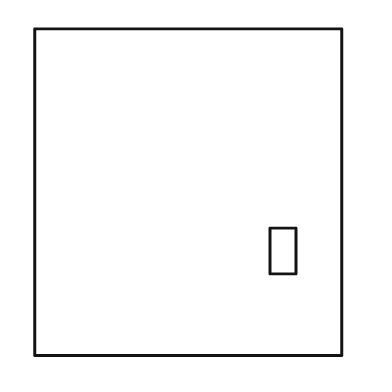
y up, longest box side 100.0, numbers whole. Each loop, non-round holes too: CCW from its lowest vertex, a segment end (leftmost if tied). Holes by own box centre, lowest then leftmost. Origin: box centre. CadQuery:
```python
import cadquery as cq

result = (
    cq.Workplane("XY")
    .moveTo(-47.0, -50.0)
    .lineTo(47.0, -50.0)
    .lineTo(47.0, 50.0)
    .lineTo(-47.0, 50.0)
    .close()
    .moveTo(25.0, -25.0)
    .lineTo(33.0, -25.0)
    .lineTo(33.0, -11.0)
    .lineTo(25.0, -11.0)
    .close()
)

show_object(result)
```